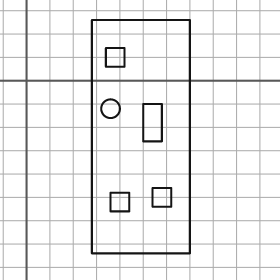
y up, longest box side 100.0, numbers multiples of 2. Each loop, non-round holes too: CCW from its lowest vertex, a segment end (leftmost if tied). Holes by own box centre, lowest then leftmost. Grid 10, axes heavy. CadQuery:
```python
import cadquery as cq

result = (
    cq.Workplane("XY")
    .moveTo(28.0, -74.0)
    .lineTo(70.0, -74.0)
    .lineTo(70.0, 26.0)
    .lineTo(28.0, 26.0)
    .close()
    .moveTo(36.0, -56.0)
    .lineTo(44.0, -56.0)
    .lineTo(44.0, -48.0)
    .lineTo(36.0, -48.0)
    .close()
    .moveTo(54.0, -54.0)
    .lineTo(62.0, -54.0)
    .lineTo(62.0, -46.0)
    .lineTo(54.0, -46.0)
    .close()
    .moveTo(50.0, -26.0)
    .lineTo(58.0, -26.0)
    .lineTo(58.0, -10.0)
    .lineTo(50.0, -10.0)
    .close()
    .moveTo(36.0, -12.0)
    .circle(4.0)
    .moveTo(34.0, 6.0)
    .lineTo(42.0, 6.0)
    .lineTo(42.0, 14.0)
    .lineTo(34.0, 14.0)
    .close()
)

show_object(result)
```